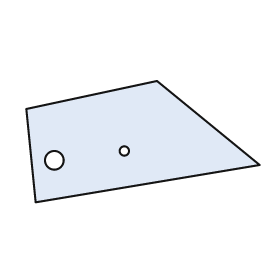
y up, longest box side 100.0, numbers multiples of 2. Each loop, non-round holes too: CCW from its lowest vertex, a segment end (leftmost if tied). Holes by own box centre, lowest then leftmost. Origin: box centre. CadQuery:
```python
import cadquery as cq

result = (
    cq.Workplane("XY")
    .moveTo(-46.0, -26.0)
    .lineTo(50.0, -10.0)
    .lineTo(6.0, 26.0)
    .lineTo(-50.0, 14.0)
    .close()
    .moveTo(-38.0, -8.0)
    .circle(4.0)
    .moveTo(-8.0, -4.0)
    .circle(2.0)
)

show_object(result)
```